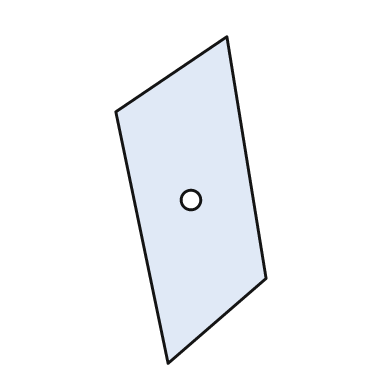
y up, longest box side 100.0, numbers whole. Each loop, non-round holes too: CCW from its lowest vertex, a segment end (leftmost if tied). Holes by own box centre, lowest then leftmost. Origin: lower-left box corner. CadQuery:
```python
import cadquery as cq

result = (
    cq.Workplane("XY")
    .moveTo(16.0, 0.0)
    .lineTo(46.0, 26.0)
    .lineTo(34.0, 100.0)
    .lineTo(0.0, 77.0)
    .close()
    .moveTo(23.0, 50.0)
    .circle(3.0)
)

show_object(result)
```